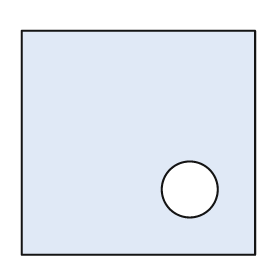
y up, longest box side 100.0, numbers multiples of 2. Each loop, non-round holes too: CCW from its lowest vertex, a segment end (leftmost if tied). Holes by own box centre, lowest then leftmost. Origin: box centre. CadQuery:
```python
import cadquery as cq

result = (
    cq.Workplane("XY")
    .moveTo(-50.0, -48.0)
    .lineTo(50.0, -48.0)
    .lineTo(50.0, 48.0)
    .lineTo(-50.0, 48.0)
    .close()
    .moveTo(22.0, -20.0)
    .circle(12.0)
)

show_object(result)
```